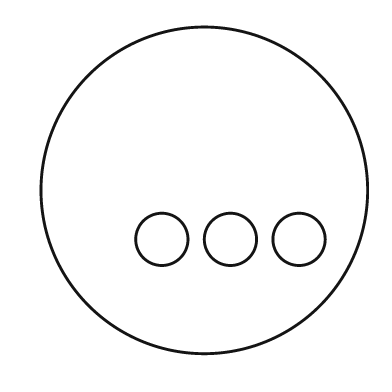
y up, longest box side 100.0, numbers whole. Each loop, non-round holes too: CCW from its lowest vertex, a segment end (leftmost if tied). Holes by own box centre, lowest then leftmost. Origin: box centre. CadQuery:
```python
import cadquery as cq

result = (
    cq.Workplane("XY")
    .moveTo(0.0, 0.0)
    .circle(50.0)
    .moveTo(-13.0, -15.0)
    .circle(8.0)
    .moveTo(8.0, -15.0)
    .circle(8.0)
    .moveTo(29.0, -15.0)
    .circle(8.0)
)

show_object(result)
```